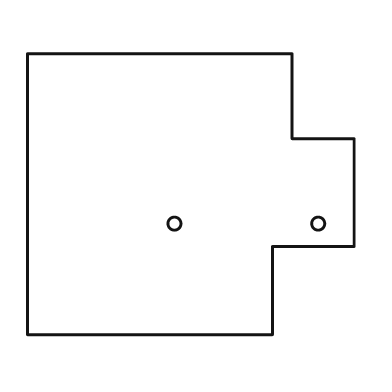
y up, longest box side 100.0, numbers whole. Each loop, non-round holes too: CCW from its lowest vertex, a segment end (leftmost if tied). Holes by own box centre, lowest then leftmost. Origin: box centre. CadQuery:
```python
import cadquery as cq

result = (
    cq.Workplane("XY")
    .moveTo(-50.0, -43.0)
    .lineTo(25.0, -43.0)
    .lineTo(25.0, -16.0)
    .lineTo(50.0, -16.0)
    .lineTo(50.0, 17.0)
    .lineTo(31.0, 17.0)
    .lineTo(31.0, 43.0)
    .lineTo(-50.0, 43.0)
    .close()
    .moveTo(-5.0, -9.0)
    .circle(2.0)
    .moveTo(39.0, -9.0)
    .circle(2.0)
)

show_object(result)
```